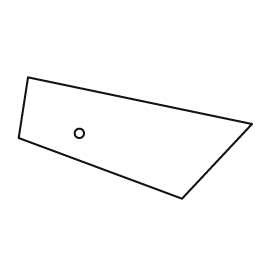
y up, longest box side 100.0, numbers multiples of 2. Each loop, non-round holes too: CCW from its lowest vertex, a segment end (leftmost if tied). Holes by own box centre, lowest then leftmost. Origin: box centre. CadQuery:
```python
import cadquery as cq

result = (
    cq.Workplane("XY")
    .moveTo(20.0, -26.0)
    .lineTo(50.0, 6.0)
    .lineTo(-46.0, 26.0)
    .lineTo(-50.0, 0.0)
    .close()
    .moveTo(-24.0, 2.0)
    .circle(2.0)
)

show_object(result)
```